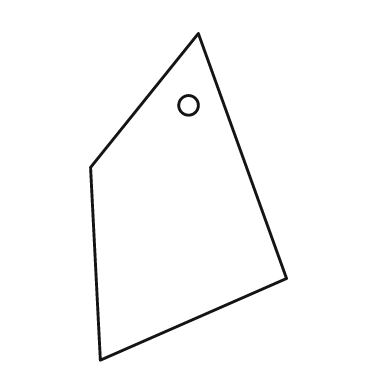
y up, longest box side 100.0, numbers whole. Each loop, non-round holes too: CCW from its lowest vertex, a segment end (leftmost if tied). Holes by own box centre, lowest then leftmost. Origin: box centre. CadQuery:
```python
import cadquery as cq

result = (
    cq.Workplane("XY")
    .moveTo(-27.0, -50.0)
    .lineTo(30.0, -25.0)
    .lineTo(3.0, 50.0)
    .lineTo(-30.0, 9.0)
    .close()
    .moveTo(0.0, 28.0)
    .circle(3.0)
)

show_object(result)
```